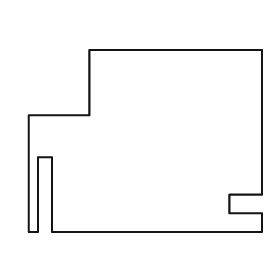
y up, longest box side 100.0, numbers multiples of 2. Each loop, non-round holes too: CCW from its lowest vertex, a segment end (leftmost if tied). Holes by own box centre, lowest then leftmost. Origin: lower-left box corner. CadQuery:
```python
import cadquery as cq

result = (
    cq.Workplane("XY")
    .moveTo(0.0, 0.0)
    .lineTo(4.0, 0.0)
    .lineTo(4.0, 32.0)
    .lineTo(10.0, 32.0)
    .lineTo(10.0, 0.0)
    .lineTo(100.0, 0.0)
    .lineTo(100.0, 8.0)
    .lineTo(86.0, 8.0)
    .lineTo(86.0, 16.0)
    .lineTo(100.0, 16.0)
    .lineTo(100.0, 78.0)
    .lineTo(26.0, 78.0)
    .lineTo(26.0, 50.0)
    .lineTo(0.0, 50.0)
    .close()
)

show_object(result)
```